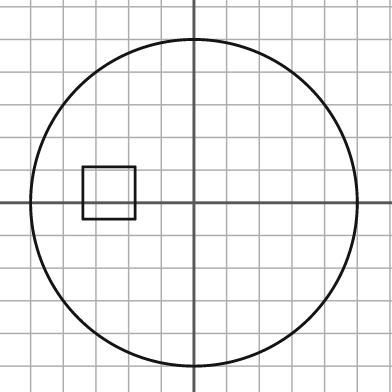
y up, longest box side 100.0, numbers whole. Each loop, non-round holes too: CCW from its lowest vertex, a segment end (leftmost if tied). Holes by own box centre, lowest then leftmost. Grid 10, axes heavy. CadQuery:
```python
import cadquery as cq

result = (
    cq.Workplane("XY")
    .moveTo(0.0, 0.0)
    .circle(50.0)
    .moveTo(-34.0, -5.0)
    .lineTo(-18.0, -5.0)
    .lineTo(-18.0, 11.0)
    .lineTo(-34.0, 11.0)
    .close()
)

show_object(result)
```